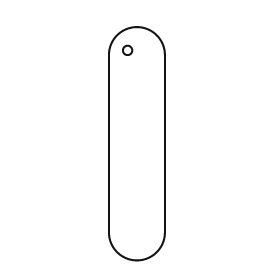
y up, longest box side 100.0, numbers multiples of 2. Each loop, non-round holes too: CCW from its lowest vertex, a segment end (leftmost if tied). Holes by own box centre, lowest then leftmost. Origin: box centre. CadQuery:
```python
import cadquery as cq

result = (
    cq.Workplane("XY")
    .moveTo(-12.0, -38.0)
    .threePointArc((0.0, -50.0), (12.0, -38.0))
    .lineTo(12.0, 38.0)
    .threePointArc((0.0, 50.0), (-12.0, 38.0))
    .close()
    .moveTo(-4.0, 40.0)
    .circle(2.0)
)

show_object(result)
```